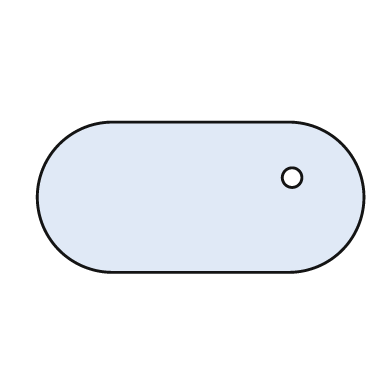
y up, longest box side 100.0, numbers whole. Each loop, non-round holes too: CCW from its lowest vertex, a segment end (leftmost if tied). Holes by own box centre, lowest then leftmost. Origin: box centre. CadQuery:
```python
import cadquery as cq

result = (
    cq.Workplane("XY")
    .moveTo(-27.0, -23.0)
    .lineTo(27.0, -23.0)
    .threePointArc((50.0, 0.0), (27.0, 23.0))
    .lineTo(-27.0, 23.0)
    .threePointArc((-50.0, 0.0), (-27.0, -23.0))
    .close()
    .moveTo(28.0, 6.0)
    .circle(3.0)
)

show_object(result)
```